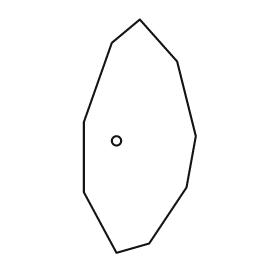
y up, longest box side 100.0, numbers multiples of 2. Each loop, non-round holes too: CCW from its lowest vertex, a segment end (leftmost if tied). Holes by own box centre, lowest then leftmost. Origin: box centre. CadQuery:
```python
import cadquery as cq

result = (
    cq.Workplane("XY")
    .moveTo(-10.0, -50.0)
    .lineTo(4.0, -46.0)
    .lineTo(20.0, -22.0)
    .lineTo(24.0, 0.0)
    .lineTo(16.0, 32.0)
    .lineTo(0.0, 50.0)
    .lineTo(-12.0, 40.0)
    .lineTo(-24.0, 6.0)
    .lineTo(-24.0, -24.0)
    .close()
    .moveTo(-10.0, -2.0)
    .circle(2.0)
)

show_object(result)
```